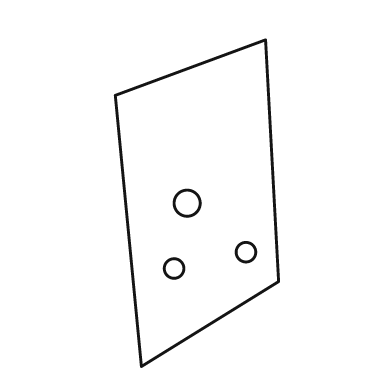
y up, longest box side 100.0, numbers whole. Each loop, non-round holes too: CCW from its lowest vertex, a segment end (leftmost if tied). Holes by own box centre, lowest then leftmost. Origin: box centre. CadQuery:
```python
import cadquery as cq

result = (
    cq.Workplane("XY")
    .moveTo(-17.0, -50.0)
    .lineTo(25.0, -24.0)
    .lineTo(21.0, 50.0)
    .lineTo(-25.0, 33.0)
    .close()
    .moveTo(-7.0, -20.0)
    .circle(3.0)
    .moveTo(15.0, -15.0)
    .circle(3.0)
    .moveTo(-3.0, 0.0)
    .circle(4.0)
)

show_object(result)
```